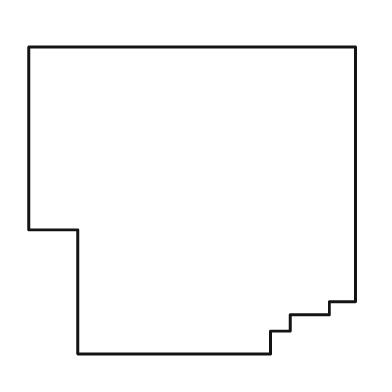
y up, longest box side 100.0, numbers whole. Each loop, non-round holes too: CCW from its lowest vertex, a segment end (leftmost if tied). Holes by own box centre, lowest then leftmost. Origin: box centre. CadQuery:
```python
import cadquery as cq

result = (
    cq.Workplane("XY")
    .moveTo(-35.0, -47.0)
    .lineTo(24.0, -47.0)
    .lineTo(24.0, -40.0)
    .lineTo(30.0, -40.0)
    .lineTo(30.0, -35.0)
    .lineTo(42.0, -35.0)
    .lineTo(42.0, -31.0)
    .lineTo(50.0, -31.0)
    .lineTo(50.0, 47.0)
    .lineTo(-50.0, 47.0)
    .lineTo(-50.0, -9.0)
    .lineTo(-35.0, -9.0)
    .close()
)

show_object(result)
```